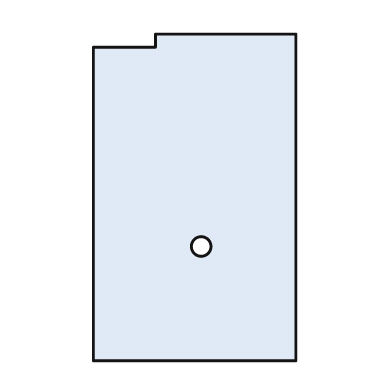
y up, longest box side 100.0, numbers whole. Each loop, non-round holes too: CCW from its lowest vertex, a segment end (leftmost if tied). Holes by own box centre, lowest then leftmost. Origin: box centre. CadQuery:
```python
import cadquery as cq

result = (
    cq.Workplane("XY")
    .moveTo(-31.0, -50.0)
    .lineTo(31.0, -50.0)
    .lineTo(31.0, 50.0)
    .lineTo(-12.0, 50.0)
    .lineTo(-12.0, 46.0)
    .lineTo(-31.0, 46.0)
    .close()
    .moveTo(2.0, -15.0)
    .circle(3.0)
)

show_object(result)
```